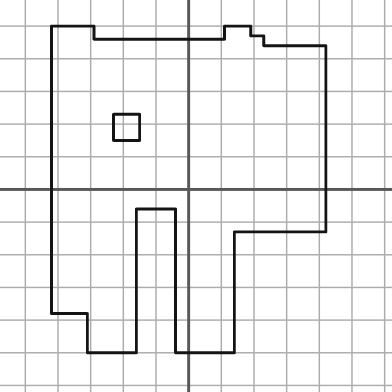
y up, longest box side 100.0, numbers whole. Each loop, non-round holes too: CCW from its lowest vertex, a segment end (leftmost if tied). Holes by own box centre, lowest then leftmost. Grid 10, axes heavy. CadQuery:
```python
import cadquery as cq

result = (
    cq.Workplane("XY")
    .moveTo(-31.0, -50.0)
    .lineTo(-16.0, -50.0)
    .lineTo(-16.0, -6.0)
    .lineTo(-4.0, -6.0)
    .lineTo(-4.0, -50.0)
    .lineTo(14.0, -50.0)
    .lineTo(14.0, -13.0)
    .lineTo(42.0, -13.0)
    .lineTo(42.0, 44.0)
    .lineTo(23.0, 44.0)
    .lineTo(23.0, 47.0)
    .lineTo(19.0, 47.0)
    .lineTo(19.0, 50.0)
    .lineTo(11.0, 50.0)
    .lineTo(11.0, 46.0)
    .lineTo(-29.0, 46.0)
    .lineTo(-29.0, 50.0)
    .lineTo(-42.0, 50.0)
    .lineTo(-42.0, -38.0)
    .lineTo(-31.0, -38.0)
    .close()
    .moveTo(-23.0, 15.0)
    .lineTo(-15.0, 15.0)
    .lineTo(-15.0, 23.0)
    .lineTo(-23.0, 23.0)
    .close()
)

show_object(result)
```